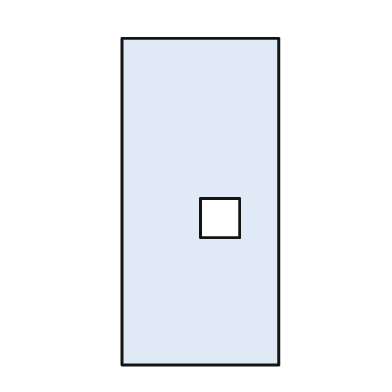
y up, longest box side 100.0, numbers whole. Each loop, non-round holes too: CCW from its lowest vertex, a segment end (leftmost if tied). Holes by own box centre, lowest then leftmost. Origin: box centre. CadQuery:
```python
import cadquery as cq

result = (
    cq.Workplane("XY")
    .moveTo(-24.0, -50.0)
    .lineTo(24.0, -50.0)
    .lineTo(24.0, 50.0)
    .lineTo(-24.0, 50.0)
    .close()
    .moveTo(0.0, -11.0)
    .lineTo(12.0, -11.0)
    .lineTo(12.0, 1.0)
    .lineTo(0.0, 1.0)
    .close()
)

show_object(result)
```